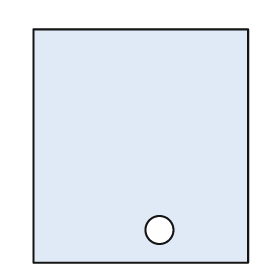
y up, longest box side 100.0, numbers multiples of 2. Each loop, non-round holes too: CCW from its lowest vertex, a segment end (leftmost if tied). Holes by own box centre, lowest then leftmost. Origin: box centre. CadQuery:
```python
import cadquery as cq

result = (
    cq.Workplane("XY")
    .moveTo(-46.0, -50.0)
    .lineTo(46.0, -50.0)
    .lineTo(46.0, 50.0)
    .lineTo(-46.0, 50.0)
    .close()
    .moveTo(8.0, -36.0)
    .circle(6.0)
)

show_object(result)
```